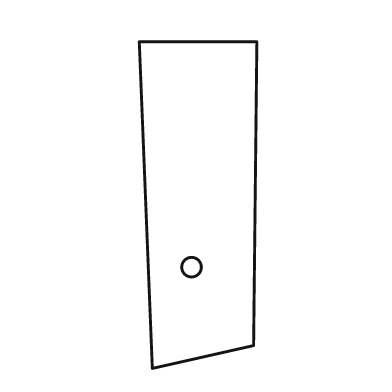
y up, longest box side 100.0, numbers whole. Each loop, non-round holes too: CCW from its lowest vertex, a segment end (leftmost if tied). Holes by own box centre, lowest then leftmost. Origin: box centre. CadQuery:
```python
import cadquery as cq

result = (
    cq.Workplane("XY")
    .moveTo(-14.0, -50.0)
    .lineTo(17.0, -43.0)
    .lineTo(18.0, 50.0)
    .lineTo(-18.0, 50.0)
    .close()
    .moveTo(-2.0, -19.0)
    .circle(3.0)
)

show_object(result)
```